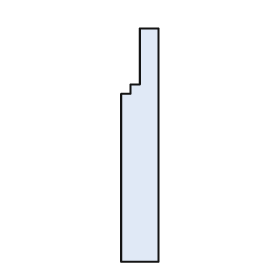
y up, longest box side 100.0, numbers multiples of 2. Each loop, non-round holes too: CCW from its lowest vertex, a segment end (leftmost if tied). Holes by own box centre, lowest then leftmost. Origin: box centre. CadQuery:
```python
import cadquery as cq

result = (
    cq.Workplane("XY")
    .moveTo(-8.0, -50.0)
    .lineTo(8.0, -50.0)
    .lineTo(8.0, 50.0)
    .lineTo(0.0, 50.0)
    .lineTo(0.0, 26.0)
    .lineTo(-4.0, 26.0)
    .lineTo(-4.0, 22.0)
    .lineTo(-8.0, 22.0)
    .close()
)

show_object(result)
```